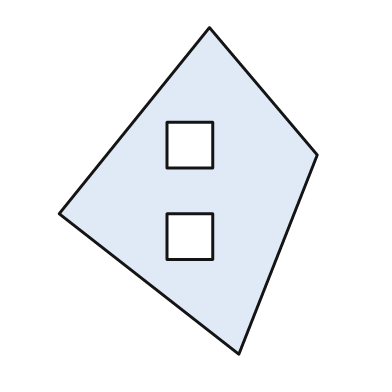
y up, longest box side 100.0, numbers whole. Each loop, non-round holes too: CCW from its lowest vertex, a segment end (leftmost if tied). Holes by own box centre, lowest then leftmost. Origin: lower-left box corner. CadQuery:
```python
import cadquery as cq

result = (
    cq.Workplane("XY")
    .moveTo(55.0, 0.0)
    .lineTo(79.0, 61.0)
    .lineTo(46.0, 100.0)
    .lineTo(0.0, 43.0)
    .close()
    .moveTo(33.0, 29.0)
    .lineTo(47.0, 29.0)
    .lineTo(47.0, 43.0)
    .lineTo(33.0, 43.0)
    .close()
    .moveTo(33.0, 57.0)
    .lineTo(47.0, 57.0)
    .lineTo(47.0, 71.0)
    .lineTo(33.0, 71.0)
    .close()
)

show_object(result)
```